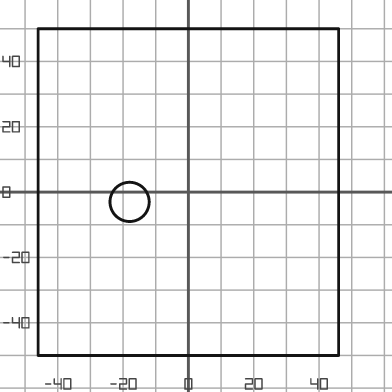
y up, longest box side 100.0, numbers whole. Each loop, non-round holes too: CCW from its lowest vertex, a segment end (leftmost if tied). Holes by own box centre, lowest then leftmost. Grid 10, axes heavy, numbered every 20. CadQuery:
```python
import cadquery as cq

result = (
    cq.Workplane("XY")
    .moveTo(-46.0, -50.0)
    .lineTo(46.0, -50.0)
    .lineTo(46.0, 50.0)
    .lineTo(-46.0, 50.0)
    .close()
    .moveTo(-18.0, -3.0)
    .circle(6.0)
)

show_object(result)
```